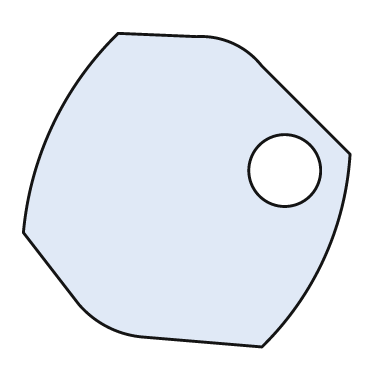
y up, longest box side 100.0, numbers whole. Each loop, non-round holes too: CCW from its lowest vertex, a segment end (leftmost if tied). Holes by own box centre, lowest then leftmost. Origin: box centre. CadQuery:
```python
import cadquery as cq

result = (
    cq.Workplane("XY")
    .moveTo(23.0, -48.0)
    .threePointArc((42.0, -21.0), (50.0, 11.0))
    .lineTo(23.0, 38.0)
    .threePointArc((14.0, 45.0), (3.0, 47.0))
    .lineTo(-21.0, 48.0)
    .threePointArc((-41.0, 20.0), (-50.0, -13.0))
    .lineTo(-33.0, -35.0)
    .threePointArc((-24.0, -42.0), (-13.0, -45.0))
    .close()
    .moveTo(30.0, 6.0)
    .circle(11.0)
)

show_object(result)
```